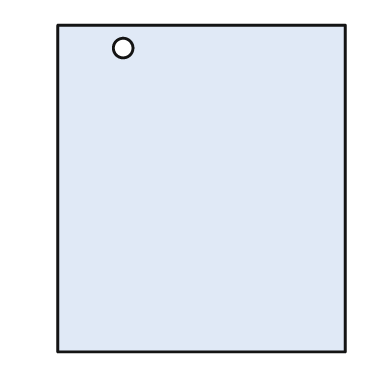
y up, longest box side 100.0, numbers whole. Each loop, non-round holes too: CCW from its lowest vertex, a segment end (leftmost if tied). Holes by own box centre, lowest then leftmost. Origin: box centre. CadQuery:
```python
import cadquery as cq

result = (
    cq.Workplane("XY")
    .moveTo(-44.0, -50.0)
    .lineTo(44.0, -50.0)
    .lineTo(44.0, 50.0)
    .lineTo(-44.0, 50.0)
    .close()
    .moveTo(-24.0, 43.0)
    .circle(3.0)
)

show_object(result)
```